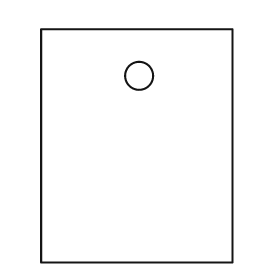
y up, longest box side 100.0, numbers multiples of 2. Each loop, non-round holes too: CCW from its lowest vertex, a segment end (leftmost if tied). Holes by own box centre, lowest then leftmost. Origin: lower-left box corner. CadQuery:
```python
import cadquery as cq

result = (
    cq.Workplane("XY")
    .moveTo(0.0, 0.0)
    .lineTo(82.0, 0.0)
    .lineTo(82.0, 100.0)
    .lineTo(0.0, 100.0)
    .close()
    .moveTo(42.0, 80.0)
    .circle(6.0)
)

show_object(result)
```